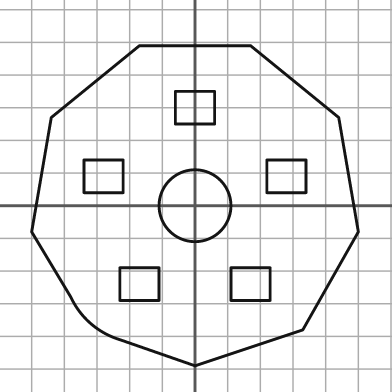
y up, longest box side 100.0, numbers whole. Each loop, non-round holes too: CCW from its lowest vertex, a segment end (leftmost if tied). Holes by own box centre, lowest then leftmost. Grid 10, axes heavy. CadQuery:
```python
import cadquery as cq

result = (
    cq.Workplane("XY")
    .moveTo(0.0, -49.0)
    .lineTo(33.0, -38.0)
    .lineTo(50.0, -8.0)
    .lineTo(44.0, 27.0)
    .lineTo(17.0, 49.0)
    .lineTo(-17.0, 49.0)
    .lineTo(-44.0, 27.0)
    .lineTo(-50.0, -8.0)
    .lineTo(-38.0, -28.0)
    .threePointArc((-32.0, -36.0), (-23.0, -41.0))
    .close()
    .moveTo(-23.0, -29.0)
    .lineTo(-11.0, -29.0)
    .lineTo(-11.0, -19.0)
    .lineTo(-23.0, -19.0)
    .close()
    .moveTo(11.0, -29.0)
    .lineTo(23.0, -29.0)
    .lineTo(23.0, -19.0)
    .lineTo(11.0, -19.0)
    .close()
    .moveTo(0.0, 0.0)
    .circle(11.0)
    .moveTo(-34.0, 4.0)
    .lineTo(-22.0, 4.0)
    .lineTo(-22.0, 14.0)
    .lineTo(-34.0, 14.0)
    .close()
    .moveTo(22.0, 4.0)
    .lineTo(34.0, 4.0)
    .lineTo(34.0, 14.0)
    .lineTo(22.0, 14.0)
    .close()
    .moveTo(-6.0, 25.0)
    .lineTo(6.0, 25.0)
    .lineTo(6.0, 35.0)
    .lineTo(-6.0, 35.0)
    .close()
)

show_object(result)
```